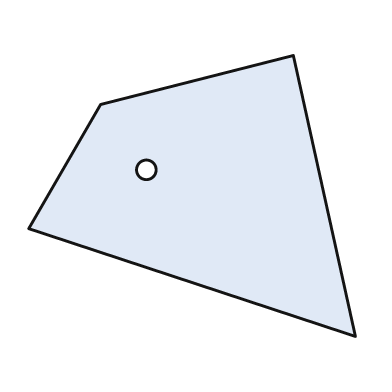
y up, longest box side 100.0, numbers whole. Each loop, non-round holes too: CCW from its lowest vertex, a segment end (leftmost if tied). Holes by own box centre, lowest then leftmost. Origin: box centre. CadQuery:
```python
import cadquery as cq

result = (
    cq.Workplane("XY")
    .moveTo(50.0, -43.0)
    .lineTo(31.0, 43.0)
    .lineTo(-28.0, 28.0)
    .lineTo(-50.0, -10.0)
    .close()
    .moveTo(-14.0, 8.0)
    .circle(3.0)
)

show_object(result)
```